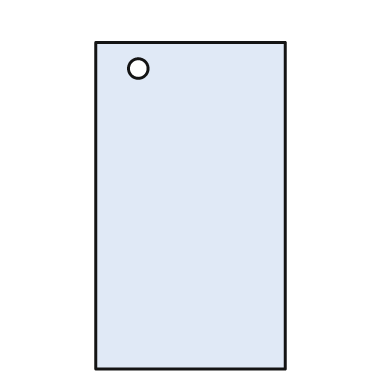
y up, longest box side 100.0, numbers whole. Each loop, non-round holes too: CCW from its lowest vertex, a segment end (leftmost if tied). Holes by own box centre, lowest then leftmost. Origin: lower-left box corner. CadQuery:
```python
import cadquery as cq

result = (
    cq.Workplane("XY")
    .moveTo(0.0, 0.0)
    .lineTo(58.0, 0.0)
    .lineTo(58.0, 100.0)
    .lineTo(0.0, 100.0)
    .close()
    .moveTo(13.0, 92.0)
    .circle(3.0)
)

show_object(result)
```